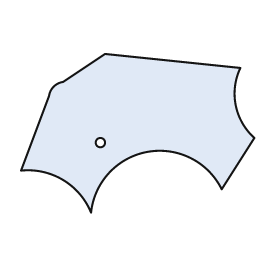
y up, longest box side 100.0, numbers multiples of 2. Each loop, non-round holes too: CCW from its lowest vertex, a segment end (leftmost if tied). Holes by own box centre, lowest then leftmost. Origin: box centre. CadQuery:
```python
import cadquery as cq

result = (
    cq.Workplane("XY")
    .moveTo(-20.0, -34.0)
    .threePointArc((4.0, -8.0), (36.0, -24.0))
    .lineTo(50.0, -2.0)
    .threePointArc((42.0, 12.0), (44.0, 28.0))
    .lineTo(-14.0, 34.0)
    .lineTo(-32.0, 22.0)
    .threePointArc((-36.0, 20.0), (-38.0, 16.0))
    .lineTo(-50.0, -16.0)
    .threePointArc((-32.0, -20.0), (-20.0, -34.0))
    .close()
    .moveTo(-16.0, -4.0)
    .circle(2.0)
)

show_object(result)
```